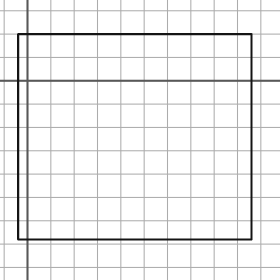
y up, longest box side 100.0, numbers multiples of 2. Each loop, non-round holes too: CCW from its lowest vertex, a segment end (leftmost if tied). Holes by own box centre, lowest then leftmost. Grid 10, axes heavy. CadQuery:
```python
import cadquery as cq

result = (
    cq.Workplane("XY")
    .moveTo(-4.0, -68.0)
    .lineTo(96.0, -68.0)
    .lineTo(96.0, 20.0)
    .lineTo(-4.0, 20.0)
    .close()
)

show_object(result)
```